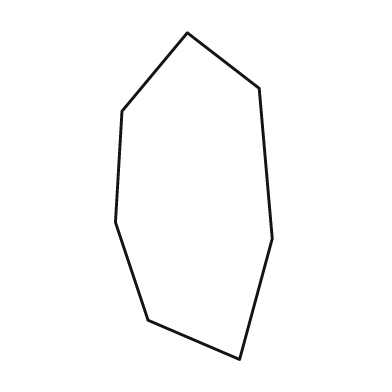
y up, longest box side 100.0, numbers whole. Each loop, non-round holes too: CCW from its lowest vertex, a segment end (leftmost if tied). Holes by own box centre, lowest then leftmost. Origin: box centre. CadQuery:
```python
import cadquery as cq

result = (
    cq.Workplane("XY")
    .moveTo(14.0, -50.0)
    .lineTo(24.0, -13.0)
    .lineTo(20.0, 33.0)
    .lineTo(-2.0, 50.0)
    .lineTo(-22.0, 26.0)
    .lineTo(-24.0, -8.0)
    .lineTo(-14.0, -38.0)
    .close()
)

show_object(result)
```